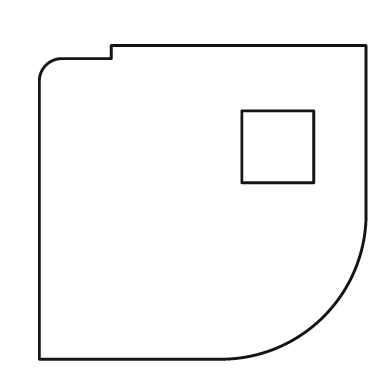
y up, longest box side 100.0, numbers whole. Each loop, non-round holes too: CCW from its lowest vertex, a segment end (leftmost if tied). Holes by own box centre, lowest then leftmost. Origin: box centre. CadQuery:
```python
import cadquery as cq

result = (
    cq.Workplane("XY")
    .moveTo(-50.0, -48.0)
    .lineTo(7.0, -48.0)
    .threePointArc((37.0, -35.0), (50.0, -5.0))
    .lineTo(50.0, 48.0)
    .lineTo(-28.0, 48.0)
    .lineTo(-28.0, 44.0)
    .lineTo(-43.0, 44.0)
    .threePointArc((-48.0, 42.0), (-50.0, 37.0))
    .close()
    .moveTo(12.0, 6.0)
    .lineTo(34.0, 6.0)
    .lineTo(34.0, 28.0)
    .lineTo(12.0, 28.0)
    .close()
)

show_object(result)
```